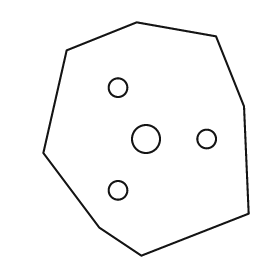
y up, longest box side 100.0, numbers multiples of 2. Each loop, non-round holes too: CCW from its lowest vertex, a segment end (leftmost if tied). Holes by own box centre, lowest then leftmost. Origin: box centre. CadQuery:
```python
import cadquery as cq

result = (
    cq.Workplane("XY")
    .moveTo(-2.0, -50.0)
    .lineTo(44.0, -32.0)
    .lineTo(42.0, 14.0)
    .lineTo(30.0, 44.0)
    .lineTo(-4.0, 50.0)
    .lineTo(-34.0, 38.0)
    .lineTo(-44.0, -6.0)
    .lineTo(-20.0, -38.0)
    .close()
    .moveTo(-12.0, -22.0)
    .circle(4.0)
    .moveTo(0.0, 0.0)
    .circle(6.0)
    .moveTo(26.0, 0.0)
    .circle(4.0)
    .moveTo(-12.0, 22.0)
    .circle(4.0)
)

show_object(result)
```